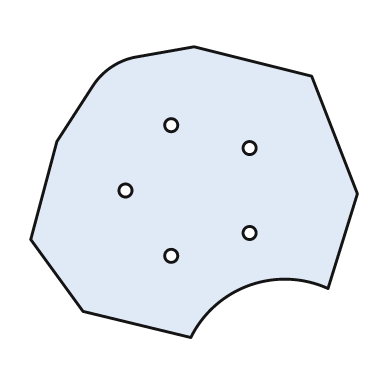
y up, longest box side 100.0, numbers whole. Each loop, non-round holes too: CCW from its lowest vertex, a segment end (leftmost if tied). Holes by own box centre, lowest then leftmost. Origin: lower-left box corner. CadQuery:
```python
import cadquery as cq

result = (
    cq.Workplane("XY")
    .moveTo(49.0, 0.0)
    .threePointArc((67.0, 16.0), (91.0, 15.0))
    .lineTo(100.0, 44.0)
    .lineTo(86.0, 80.0)
    .lineTo(50.0, 89.0)
    .lineTo(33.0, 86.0)
    .threePointArc((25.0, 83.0), (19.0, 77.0))
    .lineTo(8.0, 60.0)
    .lineTo(0.0, 30.0)
    .lineTo(16.0, 8.0)
    .close()
    .moveTo(43.0, 25.0)
    .circle(2.0)
    .moveTo(67.0, 32.0)
    .circle(2.0)
    .moveTo(29.0, 45.0)
    .circle(2.0)
    .moveTo(67.0, 58.0)
    .circle(2.0)
    .moveTo(43.0, 65.0)
    .circle(2.0)
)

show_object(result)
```